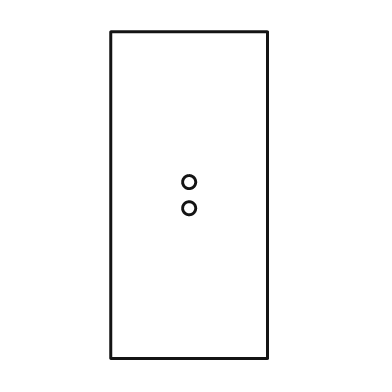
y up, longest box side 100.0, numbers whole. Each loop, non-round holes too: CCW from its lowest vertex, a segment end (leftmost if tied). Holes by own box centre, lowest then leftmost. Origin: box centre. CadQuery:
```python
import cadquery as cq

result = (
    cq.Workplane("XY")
    .moveTo(-24.0, -50.0)
    .lineTo(24.0, -50.0)
    .lineTo(24.0, 50.0)
    .lineTo(-24.0, 50.0)
    .close()
    .moveTo(0.0, -4.0)
    .circle(2.0)
    .moveTo(0.0, 4.0)
    .circle(2.0)
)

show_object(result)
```